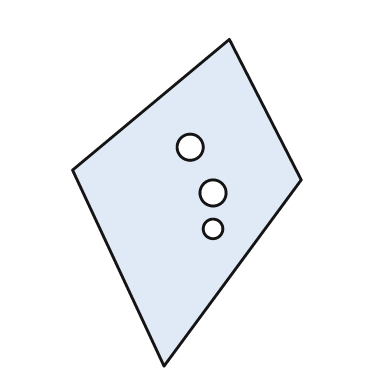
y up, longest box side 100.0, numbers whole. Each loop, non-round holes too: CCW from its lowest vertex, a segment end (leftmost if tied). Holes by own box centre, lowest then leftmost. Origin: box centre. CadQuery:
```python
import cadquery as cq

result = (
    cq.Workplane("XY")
    .moveTo(-7.0, -50.0)
    .lineTo(35.0, 7.0)
    .lineTo(13.0, 50.0)
    .lineTo(-35.0, 10.0)
    .close()
    .moveTo(8.0, -8.0)
    .circle(3.0)
    .moveTo(8.0, 3.0)
    .circle(4.0)
    .moveTo(1.0, 17.0)
    .circle(4.0)
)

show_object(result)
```